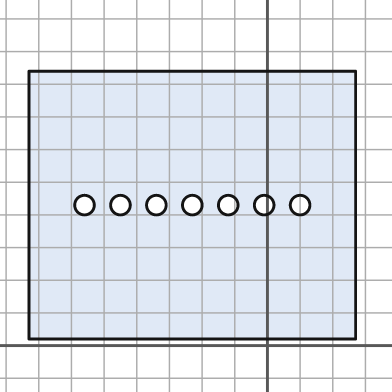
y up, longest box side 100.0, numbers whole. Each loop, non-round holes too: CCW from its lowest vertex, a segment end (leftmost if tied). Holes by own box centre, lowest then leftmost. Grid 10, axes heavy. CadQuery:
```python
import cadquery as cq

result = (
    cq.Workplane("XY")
    .moveTo(-73.0, 2.0)
    .lineTo(27.0, 2.0)
    .lineTo(27.0, 84.0)
    .lineTo(-73.0, 84.0)
    .close()
    .moveTo(-56.0, 43.0)
    .circle(3.0)
    .moveTo(-45.0, 43.0)
    .circle(3.0)
    .moveTo(-34.0, 43.0)
    .circle(3.0)
    .moveTo(-23.0, 43.0)
    .circle(3.0)
    .moveTo(-12.0, 43.0)
    .circle(3.0)
    .moveTo(-1.0, 43.0)
    .circle(3.0)
    .moveTo(10.0, 43.0)
    .circle(3.0)
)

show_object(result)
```